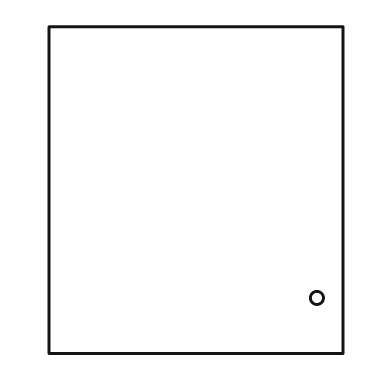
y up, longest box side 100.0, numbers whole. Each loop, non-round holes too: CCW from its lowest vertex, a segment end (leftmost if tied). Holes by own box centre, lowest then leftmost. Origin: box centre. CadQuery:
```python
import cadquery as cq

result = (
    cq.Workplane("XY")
    .moveTo(-45.0, -50.0)
    .lineTo(45.0, -50.0)
    .lineTo(45.0, 50.0)
    .lineTo(-45.0, 50.0)
    .close()
    .moveTo(37.0, -33.0)
    .circle(2.0)
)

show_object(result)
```